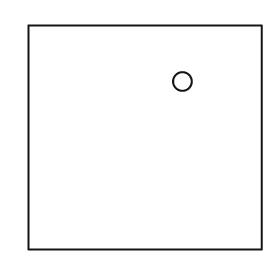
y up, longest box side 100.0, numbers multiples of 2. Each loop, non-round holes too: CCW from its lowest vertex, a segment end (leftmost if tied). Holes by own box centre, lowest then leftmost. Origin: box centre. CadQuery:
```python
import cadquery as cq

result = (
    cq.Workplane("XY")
    .moveTo(-50.0, -48.0)
    .lineTo(50.0, -48.0)
    .lineTo(50.0, 48.0)
    .lineTo(-50.0, 48.0)
    .close()
    .moveTo(16.0, 24.0)
    .circle(4.0)
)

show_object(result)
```